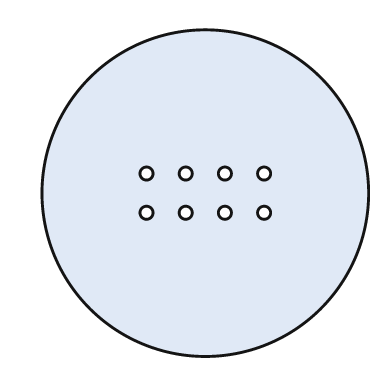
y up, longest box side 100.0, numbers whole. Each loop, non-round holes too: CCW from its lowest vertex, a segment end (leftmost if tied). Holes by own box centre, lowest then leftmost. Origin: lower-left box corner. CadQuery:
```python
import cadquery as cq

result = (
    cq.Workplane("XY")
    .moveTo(50.0, 50.0)
    .circle(50.0)
    .moveTo(32.0, 44.0)
    .circle(2.0)
    .moveTo(44.0, 44.0)
    .circle(2.0)
    .moveTo(56.0, 44.0)
    .circle(2.0)
    .moveTo(68.0, 44.0)
    .circle(2.0)
    .moveTo(32.0, 56.0)
    .circle(2.0)
    .moveTo(44.0, 56.0)
    .circle(2.0)
    .moveTo(56.0, 56.0)
    .circle(2.0)
    .moveTo(68.0, 56.0)
    .circle(2.0)
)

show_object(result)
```